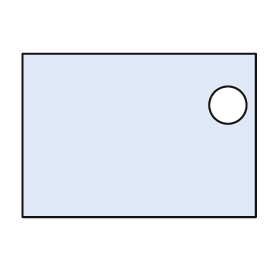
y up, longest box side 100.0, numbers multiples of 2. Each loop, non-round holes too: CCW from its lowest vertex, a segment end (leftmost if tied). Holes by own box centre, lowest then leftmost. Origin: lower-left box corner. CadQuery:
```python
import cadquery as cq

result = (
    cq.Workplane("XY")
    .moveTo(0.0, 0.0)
    .lineTo(100.0, 0.0)
    .lineTo(100.0, 70.0)
    .lineTo(0.0, 70.0)
    .close()
    .moveTo(88.0, 48.0)
    .circle(8.0)
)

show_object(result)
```